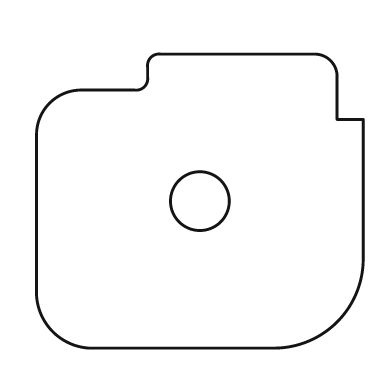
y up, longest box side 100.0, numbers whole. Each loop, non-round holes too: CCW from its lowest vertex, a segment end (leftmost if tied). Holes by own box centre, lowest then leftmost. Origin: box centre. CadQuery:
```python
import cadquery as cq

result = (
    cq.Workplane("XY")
    .moveTo(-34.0, -45.0)
    .lineTo(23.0, -45.0)
    .threePointArc((42.0, -37.0), (50.0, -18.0))
    .lineTo(50.0, 25.0)
    .lineTo(42.0, 25.0)
    .lineTo(42.0, 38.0)
    .threePointArc((40.0, 43.0), (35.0, 45.0))
    .lineTo(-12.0, 45.0)
    .threePointArc((-15.0, 44.0), (-16.0, 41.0))
    .lineTo(-16.0, 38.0)
    .threePointArc((-17.0, 35.0), (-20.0, 34.0))
    .lineTo(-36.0, 34.0)
    .threePointArc((-46.0, 30.0), (-50.0, 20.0))
    .lineTo(-50.0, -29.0)
    .threePointArc((-45.0, -40.0), (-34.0, -45.0))
    .close()
    .moveTo(0.0, 0.0)
    .circle(9.0)
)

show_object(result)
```